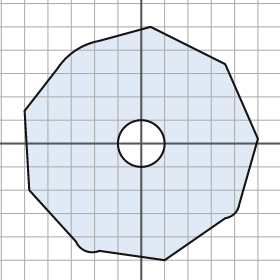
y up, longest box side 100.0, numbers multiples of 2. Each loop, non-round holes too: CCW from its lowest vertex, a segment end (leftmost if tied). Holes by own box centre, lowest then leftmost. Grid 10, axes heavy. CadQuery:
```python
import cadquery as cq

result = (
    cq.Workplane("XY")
    .moveTo(10.0, -50.0)
    .lineTo(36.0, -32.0)
    .threePointArc((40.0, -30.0), (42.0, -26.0))
    .lineTo(50.0, 2.0)
    .lineTo(36.0, 34.0)
    .lineTo(4.0, 50.0)
    .lineTo(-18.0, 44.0)
    .threePointArc((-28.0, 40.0), (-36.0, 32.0))
    .lineTo(-50.0, 14.0)
    .lineTo(-48.0, -20.0)
    .lineTo(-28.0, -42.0)
    .threePointArc((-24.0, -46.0), (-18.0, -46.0))
    .close()
    .moveTo(0.0, 0.0)
    .circle(10.0)
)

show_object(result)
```